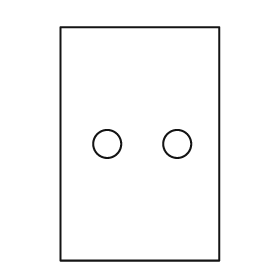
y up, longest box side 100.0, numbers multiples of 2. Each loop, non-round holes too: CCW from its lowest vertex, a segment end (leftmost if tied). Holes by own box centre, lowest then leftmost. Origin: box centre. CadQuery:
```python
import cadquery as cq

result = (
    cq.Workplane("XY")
    .moveTo(-34.0, -50.0)
    .lineTo(34.0, -50.0)
    .lineTo(34.0, 50.0)
    .lineTo(-34.0, 50.0)
    .close()
    .moveTo(-14.0, 0.0)
    .circle(6.0)
    .moveTo(16.0, 0.0)
    .circle(6.0)
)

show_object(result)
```